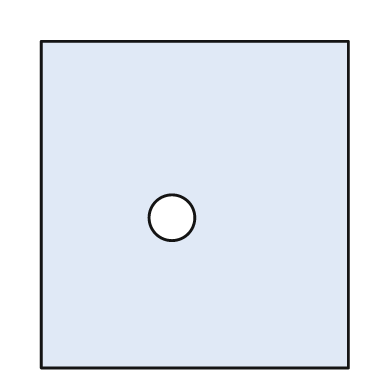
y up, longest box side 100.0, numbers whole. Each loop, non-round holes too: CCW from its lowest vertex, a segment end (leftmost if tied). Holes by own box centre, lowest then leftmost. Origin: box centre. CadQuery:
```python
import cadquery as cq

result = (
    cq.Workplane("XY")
    .moveTo(-47.0, -50.0)
    .lineTo(47.0, -50.0)
    .lineTo(47.0, 50.0)
    .lineTo(-47.0, 50.0)
    .close()
    .moveTo(-7.0, -4.0)
    .circle(7.0)
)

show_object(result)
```